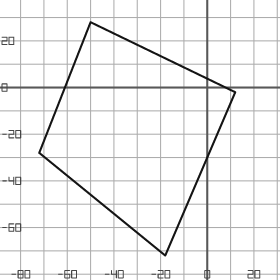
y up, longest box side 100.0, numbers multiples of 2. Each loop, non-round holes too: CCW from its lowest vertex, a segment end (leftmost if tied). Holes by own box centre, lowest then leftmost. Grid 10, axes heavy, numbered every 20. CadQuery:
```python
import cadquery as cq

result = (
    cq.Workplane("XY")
    .moveTo(-18.0, -72.0)
    .lineTo(12.0, -2.0)
    .lineTo(-50.0, 28.0)
    .lineTo(-72.0, -28.0)
    .close()
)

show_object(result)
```